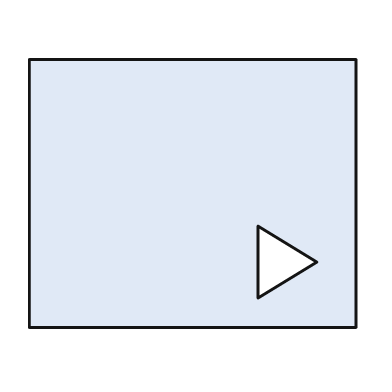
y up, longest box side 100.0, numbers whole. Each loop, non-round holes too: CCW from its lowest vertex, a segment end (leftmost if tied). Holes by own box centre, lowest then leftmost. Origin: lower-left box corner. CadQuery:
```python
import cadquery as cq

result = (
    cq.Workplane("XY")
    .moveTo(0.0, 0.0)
    .lineTo(100.0, 0.0)
    .lineTo(100.0, 82.0)
    .lineTo(0.0, 82.0)
    .close()
    .moveTo(70.0, 9.0)
    .lineTo(88.0, 20.0)
    .lineTo(70.0, 31.0)
    .close()
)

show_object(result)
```